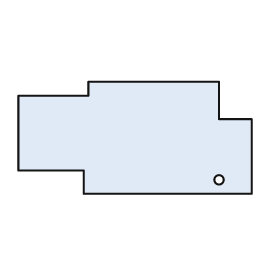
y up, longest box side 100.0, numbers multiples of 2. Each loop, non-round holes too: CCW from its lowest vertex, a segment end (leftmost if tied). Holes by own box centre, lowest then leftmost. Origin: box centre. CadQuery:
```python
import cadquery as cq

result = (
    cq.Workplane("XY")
    .moveTo(-22.0, -24.0)
    .lineTo(50.0, -24.0)
    .lineTo(50.0, 8.0)
    .lineTo(36.0, 8.0)
    .lineTo(36.0, 24.0)
    .lineTo(-20.0, 24.0)
    .lineTo(-20.0, 18.0)
    .lineTo(-50.0, 18.0)
    .lineTo(-50.0, -14.0)
    .lineTo(-22.0, -14.0)
    .close()
    .moveTo(36.0, -18.0)
    .circle(2.0)
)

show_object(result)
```